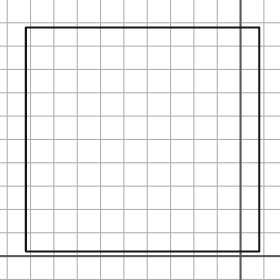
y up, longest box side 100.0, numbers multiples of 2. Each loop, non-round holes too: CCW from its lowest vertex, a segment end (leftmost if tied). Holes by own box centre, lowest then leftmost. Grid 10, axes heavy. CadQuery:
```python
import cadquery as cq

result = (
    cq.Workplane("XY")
    .moveTo(-92.0, 2.0)
    .lineTo(8.0, 2.0)
    .lineTo(8.0, 98.0)
    .lineTo(-92.0, 98.0)
    .close()
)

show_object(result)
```